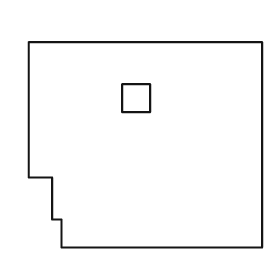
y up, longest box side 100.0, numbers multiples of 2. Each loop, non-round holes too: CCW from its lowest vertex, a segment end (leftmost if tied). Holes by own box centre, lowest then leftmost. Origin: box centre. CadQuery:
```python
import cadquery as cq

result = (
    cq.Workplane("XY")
    .moveTo(-36.0, -44.0)
    .lineTo(50.0, -44.0)
    .lineTo(50.0, 44.0)
    .lineTo(-50.0, 44.0)
    .lineTo(-50.0, -14.0)
    .lineTo(-40.0, -14.0)
    .lineTo(-40.0, -32.0)
    .lineTo(-36.0, -32.0)
    .close()
    .moveTo(-10.0, 14.0)
    .lineTo(2.0, 14.0)
    .lineTo(2.0, 26.0)
    .lineTo(-10.0, 26.0)
    .close()
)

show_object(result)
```